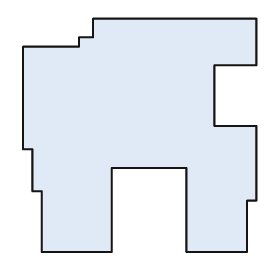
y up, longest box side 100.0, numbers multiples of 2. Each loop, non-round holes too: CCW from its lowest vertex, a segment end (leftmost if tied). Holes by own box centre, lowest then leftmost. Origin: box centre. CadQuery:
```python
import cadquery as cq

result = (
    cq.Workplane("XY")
    .moveTo(-42.0, -50.0)
    .lineTo(-12.0, -50.0)
    .lineTo(-12.0, -14.0)
    .lineTo(20.0, -14.0)
    .lineTo(20.0, -50.0)
    .lineTo(46.0, -50.0)
    .lineTo(46.0, -28.0)
    .lineTo(50.0, -28.0)
    .lineTo(50.0, 4.0)
    .lineTo(32.0, 4.0)
    .lineTo(32.0, 30.0)
    .lineTo(50.0, 30.0)
    .lineTo(50.0, 50.0)
    .lineTo(-20.0, 50.0)
    .lineTo(-20.0, 42.0)
    .lineTo(-26.0, 42.0)
    .lineTo(-26.0, 38.0)
    .lineTo(-50.0, 38.0)
    .lineTo(-50.0, -6.0)
    .lineTo(-46.0, -6.0)
    .lineTo(-46.0, -24.0)
    .lineTo(-42.0, -24.0)
    .close()
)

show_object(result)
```